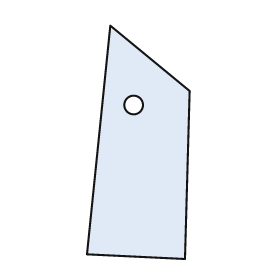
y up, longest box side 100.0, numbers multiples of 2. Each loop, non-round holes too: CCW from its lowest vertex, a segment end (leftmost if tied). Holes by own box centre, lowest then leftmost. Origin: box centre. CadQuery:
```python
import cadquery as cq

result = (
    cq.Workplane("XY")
    .moveTo(20.0, -50.0)
    .lineTo(22.0, 22.0)
    .lineTo(-12.0, 50.0)
    .lineTo(-22.0, -48.0)
    .close()
    .moveTo(-2.0, 16.0)
    .circle(4.0)
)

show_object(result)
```